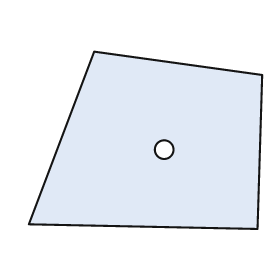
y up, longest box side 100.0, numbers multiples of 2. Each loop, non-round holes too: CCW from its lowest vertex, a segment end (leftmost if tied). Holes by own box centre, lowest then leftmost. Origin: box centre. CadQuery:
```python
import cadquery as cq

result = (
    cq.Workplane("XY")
    .moveTo(48.0, -38.0)
    .lineTo(50.0, 28.0)
    .lineTo(-22.0, 38.0)
    .lineTo(-50.0, -36.0)
    .close()
    .moveTo(8.0, -4.0)
    .circle(4.0)
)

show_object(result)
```